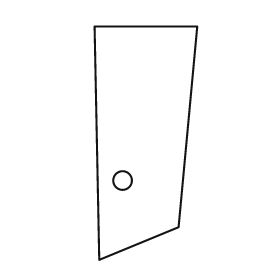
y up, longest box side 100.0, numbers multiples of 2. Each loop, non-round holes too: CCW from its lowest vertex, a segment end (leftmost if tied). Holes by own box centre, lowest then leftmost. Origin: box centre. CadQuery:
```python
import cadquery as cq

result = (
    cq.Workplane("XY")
    .moveTo(-20.0, -50.0)
    .lineTo(14.0, -36.0)
    .lineTo(22.0, 50.0)
    .lineTo(-22.0, 50.0)
    .close()
    .moveTo(-10.0, -16.0)
    .circle(4.0)
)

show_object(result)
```